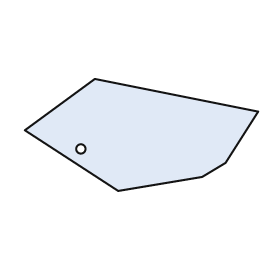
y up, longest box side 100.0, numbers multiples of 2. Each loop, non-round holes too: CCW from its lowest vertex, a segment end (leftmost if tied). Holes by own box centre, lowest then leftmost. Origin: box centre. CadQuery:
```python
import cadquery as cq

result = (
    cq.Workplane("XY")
    .moveTo(-10.0, -24.0)
    .lineTo(26.0, -18.0)
    .lineTo(36.0, -12.0)
    .lineTo(50.0, 10.0)
    .lineTo(-20.0, 24.0)
    .lineTo(-50.0, 2.0)
    .close()
    .moveTo(-26.0, -6.0)
    .circle(2.0)
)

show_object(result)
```